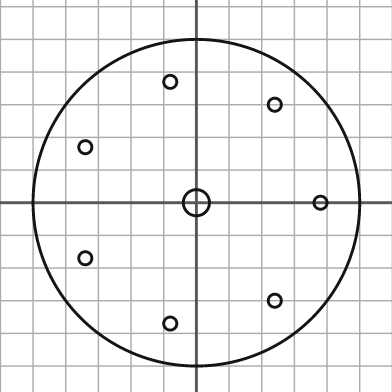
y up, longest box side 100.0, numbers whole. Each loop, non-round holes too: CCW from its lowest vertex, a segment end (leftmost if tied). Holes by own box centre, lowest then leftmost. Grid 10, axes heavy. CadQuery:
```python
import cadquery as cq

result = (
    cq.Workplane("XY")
    .moveTo(0.0, 0.0)
    .circle(50.0)
    .moveTo(-8.0, -37.0)
    .circle(2.0)
    .moveTo(24.0, -30.0)
    .circle(2.0)
    .moveTo(-34.0, -17.0)
    .circle(2.0)
    .moveTo(0.0, 0.0)
    .circle(4.0)
    .moveTo(38.0, 0.0)
    .circle(2.0)
    .moveTo(-34.0, 17.0)
    .circle(2.0)
    .moveTo(24.0, 30.0)
    .circle(2.0)
    .moveTo(-8.0, 37.0)
    .circle(2.0)
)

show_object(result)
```